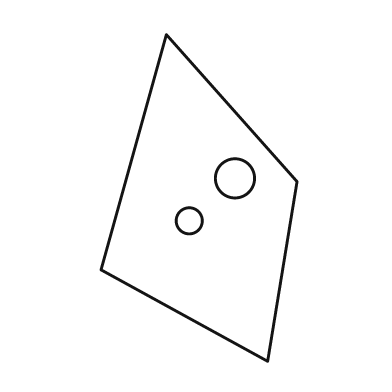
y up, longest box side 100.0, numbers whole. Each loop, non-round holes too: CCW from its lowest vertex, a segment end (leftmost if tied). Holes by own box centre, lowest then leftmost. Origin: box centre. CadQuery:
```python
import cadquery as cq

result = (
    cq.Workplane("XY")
    .moveTo(21.0, -50.0)
    .lineTo(30.0, 5.0)
    .lineTo(-10.0, 50.0)
    .lineTo(-30.0, -22.0)
    .close()
    .moveTo(-3.0, -7.0)
    .circle(4.0)
    .moveTo(11.0, 6.0)
    .circle(6.0)
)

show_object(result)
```